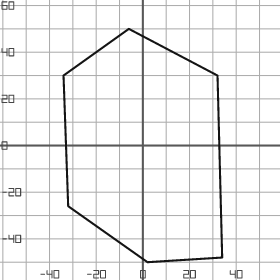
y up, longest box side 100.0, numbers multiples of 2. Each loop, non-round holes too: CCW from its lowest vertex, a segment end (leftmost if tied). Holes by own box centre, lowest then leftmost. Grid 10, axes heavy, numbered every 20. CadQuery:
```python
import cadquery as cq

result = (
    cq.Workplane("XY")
    .moveTo(2.0, -50.0)
    .lineTo(34.0, -48.0)
    .lineTo(32.0, 30.0)
    .lineTo(-6.0, 50.0)
    .lineTo(-34.0, 30.0)
    .lineTo(-32.0, -26.0)
    .close()
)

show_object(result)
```